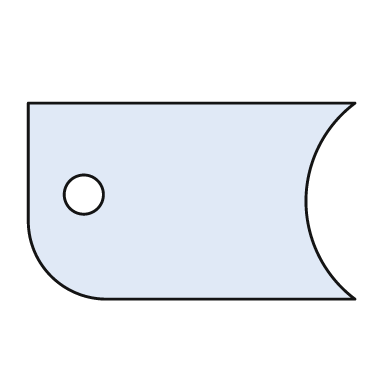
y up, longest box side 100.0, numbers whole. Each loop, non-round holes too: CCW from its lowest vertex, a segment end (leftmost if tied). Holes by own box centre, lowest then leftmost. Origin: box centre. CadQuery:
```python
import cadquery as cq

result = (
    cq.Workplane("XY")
    .moveTo(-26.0, -30.0)
    .lineTo(50.0, -30.0)
    .threePointArc((35.0, 0.0), (50.0, 30.0))
    .lineTo(-50.0, 30.0)
    .lineTo(-50.0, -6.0)
    .threePointArc((-43.0, -23.0), (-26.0, -30.0))
    .close()
    .moveTo(-33.0, 2.0)
    .circle(6.0)
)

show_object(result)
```